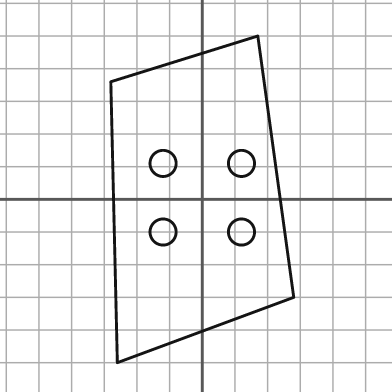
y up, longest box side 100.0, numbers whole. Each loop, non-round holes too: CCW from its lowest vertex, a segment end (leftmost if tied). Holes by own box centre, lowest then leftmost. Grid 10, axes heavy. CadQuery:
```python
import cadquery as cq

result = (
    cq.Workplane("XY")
    .moveTo(-26.0, -50.0)
    .lineTo(28.0, -30.0)
    .lineTo(17.0, 50.0)
    .lineTo(-28.0, 36.0)
    .close()
    .moveTo(-12.0, -10.0)
    .circle(4.0)
    .moveTo(12.0, -10.0)
    .circle(4.0)
    .moveTo(-12.0, 11.0)
    .circle(4.0)
    .moveTo(12.0, 11.0)
    .circle(4.0)
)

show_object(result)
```